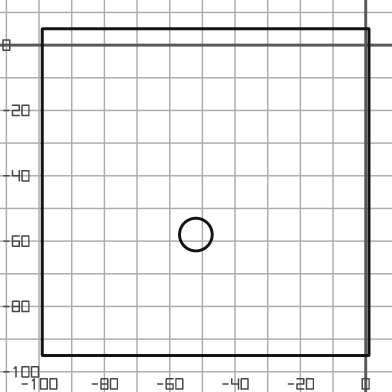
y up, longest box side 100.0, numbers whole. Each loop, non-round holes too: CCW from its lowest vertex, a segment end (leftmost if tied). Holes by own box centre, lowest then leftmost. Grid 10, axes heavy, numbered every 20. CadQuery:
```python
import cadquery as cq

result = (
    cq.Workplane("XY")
    .moveTo(-99.0, -95.0)
    .lineTo(1.0, -95.0)
    .lineTo(1.0, 5.0)
    .lineTo(-99.0, 5.0)
    .close()
    .moveTo(-52.0, -58.0)
    .circle(5.0)
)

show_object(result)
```